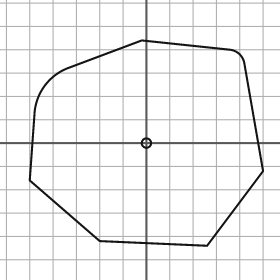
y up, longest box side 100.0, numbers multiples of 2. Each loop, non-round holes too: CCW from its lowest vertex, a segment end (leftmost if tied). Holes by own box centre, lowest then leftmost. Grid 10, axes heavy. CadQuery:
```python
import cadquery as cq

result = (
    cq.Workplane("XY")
    .moveTo(26.0, -44.0)
    .lineTo(50.0, -12.0)
    .lineTo(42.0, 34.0)
    .threePointArc((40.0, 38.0), (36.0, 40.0))
    .lineTo(-2.0, 44.0)
    .lineTo(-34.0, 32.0)
    .threePointArc((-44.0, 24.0), (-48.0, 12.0))
    .lineTo(-50.0, -16.0)
    .lineTo(-20.0, -42.0)
    .close()
    .moveTo(0.0, 0.0)
    .circle(2.0)
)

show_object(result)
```